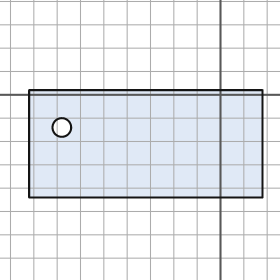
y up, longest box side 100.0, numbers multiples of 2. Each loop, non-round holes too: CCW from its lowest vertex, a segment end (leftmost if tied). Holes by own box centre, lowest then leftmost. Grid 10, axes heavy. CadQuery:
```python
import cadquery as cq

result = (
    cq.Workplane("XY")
    .moveTo(-82.0, -44.0)
    .lineTo(18.0, -44.0)
    .lineTo(18.0, 2.0)
    .lineTo(-82.0, 2.0)
    .close()
    .moveTo(-68.0, -14.0)
    .circle(4.0)
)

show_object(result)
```